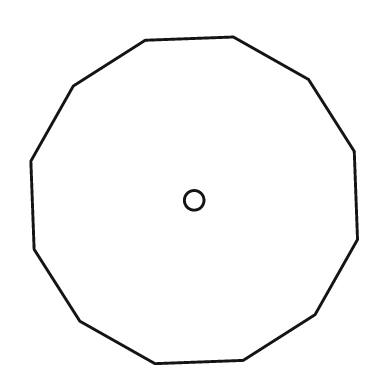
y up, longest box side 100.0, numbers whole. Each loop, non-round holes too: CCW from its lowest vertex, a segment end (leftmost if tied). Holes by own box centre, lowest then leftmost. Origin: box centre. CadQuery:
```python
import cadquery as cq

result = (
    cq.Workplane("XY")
    .moveTo(-12.0, -50.0)
    .lineTo(15.0, -49.0)
    .lineTo(37.0, -35.0)
    .lineTo(50.0, -12.0)
    .lineTo(49.0, 15.0)
    .lineTo(35.0, 37.0)
    .lineTo(12.0, 50.0)
    .lineTo(-15.0, 49.0)
    .lineTo(-37.0, 35.0)
    .lineTo(-50.0, 12.0)
    .lineTo(-49.0, -15.0)
    .lineTo(-35.0, -37.0)
    .close()
    .moveTo(0.0, 0.0)
    .circle(3.0)
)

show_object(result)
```